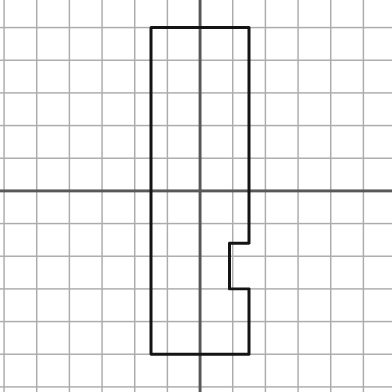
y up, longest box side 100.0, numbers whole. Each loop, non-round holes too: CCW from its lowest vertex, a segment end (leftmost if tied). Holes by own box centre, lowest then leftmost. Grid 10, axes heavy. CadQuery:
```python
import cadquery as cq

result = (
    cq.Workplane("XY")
    .moveTo(-15.0, -50.0)
    .lineTo(15.0, -50.0)
    .lineTo(15.0, -30.0)
    .lineTo(9.0, -30.0)
    .lineTo(9.0, -16.0)
    .lineTo(15.0, -16.0)
    .lineTo(15.0, 50.0)
    .lineTo(-15.0, 50.0)
    .close()
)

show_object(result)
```